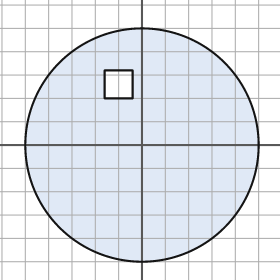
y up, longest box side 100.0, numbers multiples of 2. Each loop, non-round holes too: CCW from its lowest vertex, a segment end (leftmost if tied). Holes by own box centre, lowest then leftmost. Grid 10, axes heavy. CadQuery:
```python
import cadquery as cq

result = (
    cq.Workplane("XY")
    .moveTo(0.0, 0.0)
    .circle(50.0)
    .moveTo(-16.0, 20.0)
    .lineTo(-4.0, 20.0)
    .lineTo(-4.0, 32.0)
    .lineTo(-16.0, 32.0)
    .close()
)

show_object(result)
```